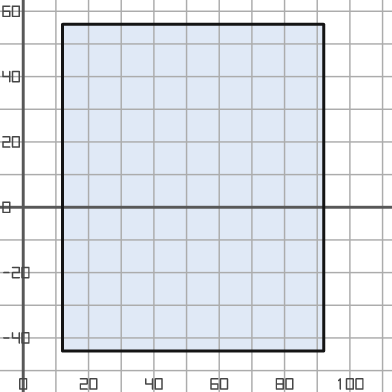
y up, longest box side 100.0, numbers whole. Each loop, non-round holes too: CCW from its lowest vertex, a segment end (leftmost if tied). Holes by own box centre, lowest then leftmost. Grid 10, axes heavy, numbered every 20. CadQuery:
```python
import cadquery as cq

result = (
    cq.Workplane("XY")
    .moveTo(12.0, -44.0)
    .lineTo(92.0, -44.0)
    .lineTo(92.0, 56.0)
    .lineTo(12.0, 56.0)
    .close()
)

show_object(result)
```